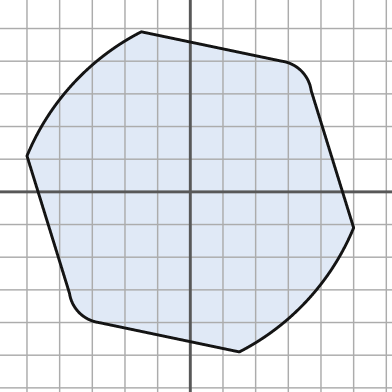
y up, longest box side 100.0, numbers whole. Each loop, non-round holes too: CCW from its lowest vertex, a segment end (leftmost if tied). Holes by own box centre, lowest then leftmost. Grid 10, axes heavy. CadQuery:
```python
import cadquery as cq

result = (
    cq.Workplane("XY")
    .moveTo(15.0, -49.0)
    .threePointArc((36.0, -33.0), (50.0, -11.0))
    .lineTo(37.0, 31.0)
    .threePointArc((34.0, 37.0), (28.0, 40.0))
    .lineTo(-15.0, 49.0)
    .threePointArc((-36.0, 33.0), (-50.0, 11.0))
    .lineTo(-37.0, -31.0)
    .threePointArc((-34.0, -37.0), (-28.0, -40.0))
    .close()
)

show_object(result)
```